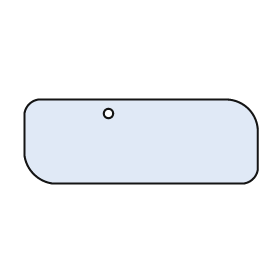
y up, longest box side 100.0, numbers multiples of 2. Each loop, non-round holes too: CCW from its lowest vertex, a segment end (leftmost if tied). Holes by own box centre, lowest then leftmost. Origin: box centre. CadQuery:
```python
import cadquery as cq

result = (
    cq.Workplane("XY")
    .moveTo(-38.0, -18.0)
    .lineTo(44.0, -18.0)
    .threePointArc((48.0, -16.0), (50.0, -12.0))
    .lineTo(50.0, 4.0)
    .threePointArc((46.0, 14.0), (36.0, 18.0))
    .lineTo(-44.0, 18.0)
    .threePointArc((-48.0, 16.0), (-50.0, 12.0))
    .lineTo(-50.0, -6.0)
    .threePointArc((-46.0, -14.0), (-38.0, -18.0))
    .close()
    .moveTo(-14.0, 12.0)
    .circle(2.0)
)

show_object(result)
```